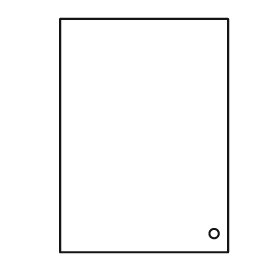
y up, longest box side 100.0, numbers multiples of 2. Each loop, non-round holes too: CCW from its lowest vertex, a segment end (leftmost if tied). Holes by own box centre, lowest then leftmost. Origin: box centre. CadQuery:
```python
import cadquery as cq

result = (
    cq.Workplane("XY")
    .moveTo(-36.0, -50.0)
    .lineTo(36.0, -50.0)
    .lineTo(36.0, 50.0)
    .lineTo(-36.0, 50.0)
    .close()
    .moveTo(30.0, -42.0)
    .circle(2.0)
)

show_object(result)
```